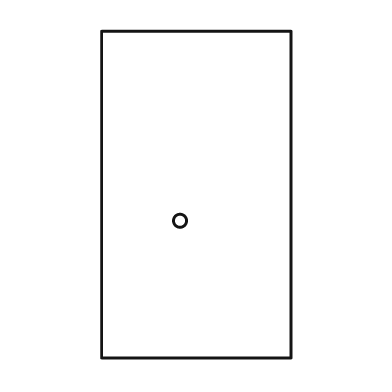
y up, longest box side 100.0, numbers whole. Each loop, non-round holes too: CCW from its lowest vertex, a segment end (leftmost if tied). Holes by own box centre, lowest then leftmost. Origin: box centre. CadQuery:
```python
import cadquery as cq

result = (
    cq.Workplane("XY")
    .moveTo(-29.0, -50.0)
    .lineTo(29.0, -50.0)
    .lineTo(29.0, 50.0)
    .lineTo(-29.0, 50.0)
    .close()
    .moveTo(-5.0, -8.0)
    .circle(2.0)
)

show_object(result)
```